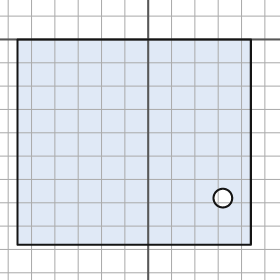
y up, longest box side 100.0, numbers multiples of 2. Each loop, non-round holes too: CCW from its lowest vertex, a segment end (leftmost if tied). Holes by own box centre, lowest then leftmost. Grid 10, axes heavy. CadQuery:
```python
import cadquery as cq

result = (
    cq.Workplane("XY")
    .moveTo(-56.0, -88.0)
    .lineTo(44.0, -88.0)
    .lineTo(44.0, 0.0)
    .lineTo(-56.0, 0.0)
    .close()
    .moveTo(32.0, -68.0)
    .circle(4.0)
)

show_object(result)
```